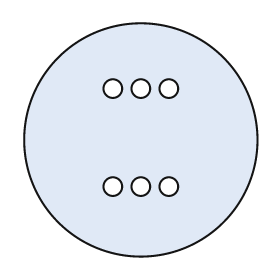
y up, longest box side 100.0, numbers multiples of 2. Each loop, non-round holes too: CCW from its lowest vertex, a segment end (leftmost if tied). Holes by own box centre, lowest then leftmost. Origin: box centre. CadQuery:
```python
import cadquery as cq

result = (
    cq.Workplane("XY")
    .moveTo(0.0, 0.0)
    .circle(50.0)
    .moveTo(-12.0, -20.0)
    .circle(4.0)
    .moveTo(0.0, -20.0)
    .circle(4.0)
    .moveTo(12.0, -20.0)
    .circle(4.0)
    .moveTo(-12.0, 22.0)
    .circle(4.0)
    .moveTo(0.0, 22.0)
    .circle(4.0)
    .moveTo(12.0, 22.0)
    .circle(4.0)
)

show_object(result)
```